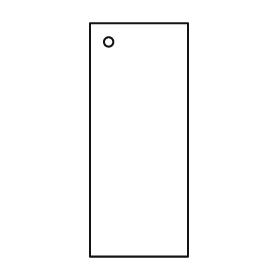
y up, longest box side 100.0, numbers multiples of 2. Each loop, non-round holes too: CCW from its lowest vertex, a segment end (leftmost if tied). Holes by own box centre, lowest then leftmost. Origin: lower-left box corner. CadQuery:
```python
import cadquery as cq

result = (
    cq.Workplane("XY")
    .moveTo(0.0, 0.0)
    .lineTo(42.0, 0.0)
    .lineTo(42.0, 100.0)
    .lineTo(0.0, 100.0)
    .close()
    .moveTo(8.0, 92.0)
    .circle(2.0)
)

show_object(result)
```